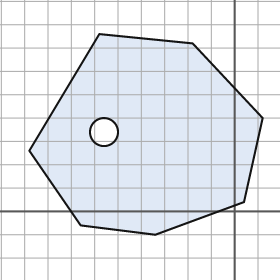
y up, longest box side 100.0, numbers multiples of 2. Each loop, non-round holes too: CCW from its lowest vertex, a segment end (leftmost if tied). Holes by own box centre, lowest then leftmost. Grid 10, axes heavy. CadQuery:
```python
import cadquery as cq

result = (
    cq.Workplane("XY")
    .moveTo(-34.0, -10.0)
    .lineTo(4.0, 4.0)
    .lineTo(12.0, 40.0)
    .lineTo(-18.0, 72.0)
    .lineTo(-58.0, 76.0)
    .lineTo(-88.0, 26.0)
    .lineTo(-66.0, -6.0)
    .close()
    .moveTo(-56.0, 34.0)
    .circle(6.0)
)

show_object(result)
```